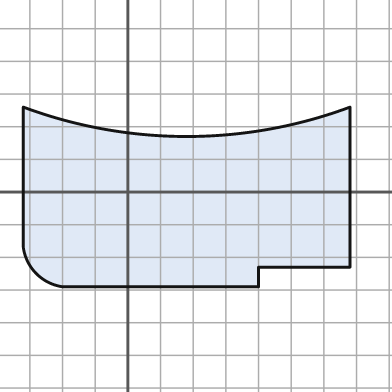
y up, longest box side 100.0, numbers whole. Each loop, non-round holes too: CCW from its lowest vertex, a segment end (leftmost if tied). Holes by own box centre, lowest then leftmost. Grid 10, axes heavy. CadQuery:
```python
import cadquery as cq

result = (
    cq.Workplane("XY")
    .moveTo(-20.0, -29.0)
    .lineTo(40.0, -29.0)
    .lineTo(40.0, -23.0)
    .lineTo(68.0, -23.0)
    .lineTo(68.0, 26.0)
    .threePointArc((18.0, 17.0), (-32.0, 26.0))
    .lineTo(-32.0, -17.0)
    .threePointArc((-28.0, -25.0), (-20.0, -29.0))
    .close()
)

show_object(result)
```